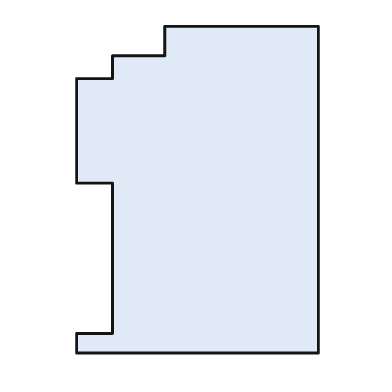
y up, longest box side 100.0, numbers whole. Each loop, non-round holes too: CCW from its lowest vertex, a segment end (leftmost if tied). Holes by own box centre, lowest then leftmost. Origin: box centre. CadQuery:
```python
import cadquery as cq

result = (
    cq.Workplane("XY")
    .moveTo(-37.0, -50.0)
    .lineTo(37.0, -50.0)
    .lineTo(37.0, 50.0)
    .lineTo(-10.0, 50.0)
    .lineTo(-10.0, 41.0)
    .lineTo(-26.0, 41.0)
    .lineTo(-26.0, 34.0)
    .lineTo(-37.0, 34.0)
    .lineTo(-37.0, 2.0)
    .lineTo(-26.0, 2.0)
    .lineTo(-26.0, -44.0)
    .lineTo(-37.0, -44.0)
    .close()
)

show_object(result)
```